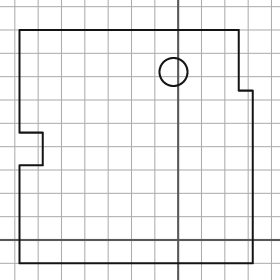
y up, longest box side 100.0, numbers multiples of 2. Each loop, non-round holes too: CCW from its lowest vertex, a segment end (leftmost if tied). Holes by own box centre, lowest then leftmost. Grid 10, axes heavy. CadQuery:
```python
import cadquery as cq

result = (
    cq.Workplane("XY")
    .moveTo(-68.0, -10.0)
    .lineTo(32.0, -10.0)
    .lineTo(32.0, 64.0)
    .lineTo(26.0, 64.0)
    .lineTo(26.0, 90.0)
    .lineTo(-68.0, 90.0)
    .lineTo(-68.0, 46.0)
    .lineTo(-58.0, 46.0)
    .lineTo(-58.0, 32.0)
    .lineTo(-68.0, 32.0)
    .close()
    .moveTo(-2.0, 72.0)
    .circle(6.0)
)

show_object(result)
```